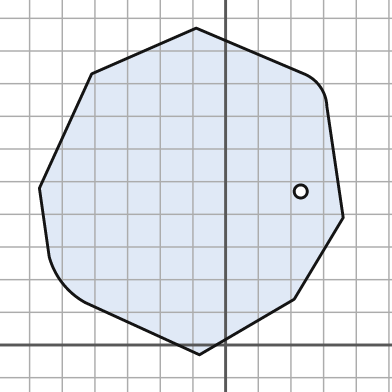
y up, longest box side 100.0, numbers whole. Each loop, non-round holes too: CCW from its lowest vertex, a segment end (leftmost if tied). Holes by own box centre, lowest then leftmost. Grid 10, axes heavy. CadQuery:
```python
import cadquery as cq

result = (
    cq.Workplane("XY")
    .moveTo(-8.0, -3.0)
    .lineTo(21.0, 14.0)
    .lineTo(36.0, 39.0)
    .lineTo(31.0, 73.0)
    .threePointArc((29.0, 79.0), (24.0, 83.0))
    .lineTo(-9.0, 97.0)
    .lineTo(-41.0, 83.0)
    .lineTo(-57.0, 48.0)
    .lineTo(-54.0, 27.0)
    .threePointArc((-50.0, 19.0), (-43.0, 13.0))
    .close()
    .moveTo(23.0, 47.0)
    .circle(2.0)
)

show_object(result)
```